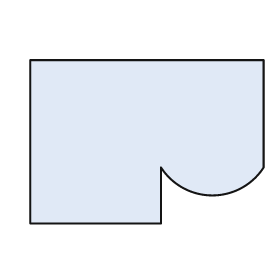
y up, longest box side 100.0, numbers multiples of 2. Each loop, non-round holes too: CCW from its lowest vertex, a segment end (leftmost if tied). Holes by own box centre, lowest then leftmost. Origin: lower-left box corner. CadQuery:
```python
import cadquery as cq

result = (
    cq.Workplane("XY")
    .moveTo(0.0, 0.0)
    .lineTo(56.0, 0.0)
    .lineTo(56.0, 24.0)
    .threePointArc((78.0, 12.0), (100.0, 24.0))
    .lineTo(100.0, 70.0)
    .lineTo(0.0, 70.0)
    .close()
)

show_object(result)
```